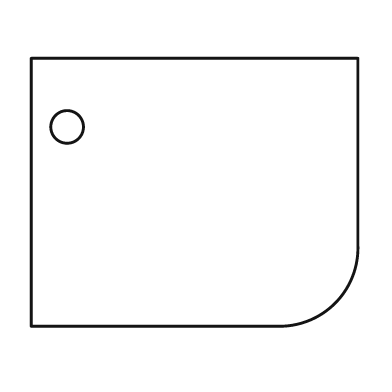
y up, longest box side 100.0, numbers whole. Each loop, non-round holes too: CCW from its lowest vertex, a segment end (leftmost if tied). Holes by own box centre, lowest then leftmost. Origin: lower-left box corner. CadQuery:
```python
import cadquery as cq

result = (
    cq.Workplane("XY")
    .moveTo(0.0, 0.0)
    .lineTo(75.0, 0.0)
    .threePointArc((93.0, 7.0), (100.0, 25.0))
    .lineTo(100.0, 82.0)
    .lineTo(0.0, 82.0)
    .close()
    .moveTo(11.0, 61.0)
    .circle(5.0)
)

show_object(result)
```